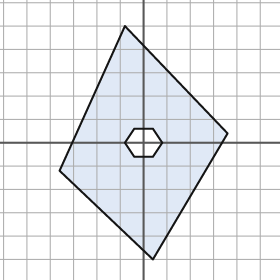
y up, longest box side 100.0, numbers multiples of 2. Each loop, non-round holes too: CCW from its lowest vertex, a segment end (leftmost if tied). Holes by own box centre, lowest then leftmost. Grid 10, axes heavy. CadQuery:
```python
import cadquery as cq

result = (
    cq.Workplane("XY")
    .moveTo(4.0, -50.0)
    .lineTo(36.0, 4.0)
    .lineTo(-8.0, 50.0)
    .lineTo(-36.0, -12.0)
    .close()
    .moveTo(-4.0, -6.0)
    .lineTo(4.0, -6.0)
    .lineTo(8.0, 0.0)
    .lineTo(4.0, 6.0)
    .lineTo(-4.0, 6.0)
    .lineTo(-8.0, 0.0)
    .close()
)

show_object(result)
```